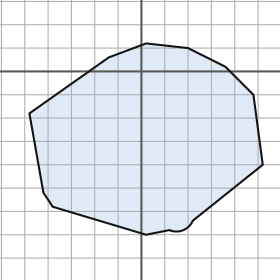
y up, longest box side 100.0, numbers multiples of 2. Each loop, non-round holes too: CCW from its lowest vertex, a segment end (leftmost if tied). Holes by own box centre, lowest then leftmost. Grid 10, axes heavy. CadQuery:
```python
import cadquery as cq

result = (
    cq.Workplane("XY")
    .moveTo(2.0, -70.0)
    .lineTo(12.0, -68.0)
    .threePointArc((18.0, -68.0), (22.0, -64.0))
    .lineTo(52.0, -40.0)
    .lineTo(48.0, -10.0)
    .lineTo(36.0, 2.0)
    .lineTo(20.0, 10.0)
    .lineTo(2.0, 12.0)
    .lineTo(-14.0, 6.0)
    .lineTo(-48.0, -18.0)
    .lineTo(-42.0, -52.0)
    .lineTo(-38.0, -58.0)
    .close()
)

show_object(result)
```